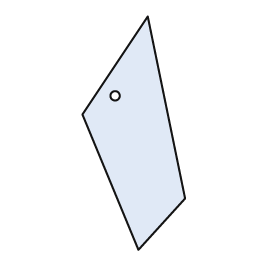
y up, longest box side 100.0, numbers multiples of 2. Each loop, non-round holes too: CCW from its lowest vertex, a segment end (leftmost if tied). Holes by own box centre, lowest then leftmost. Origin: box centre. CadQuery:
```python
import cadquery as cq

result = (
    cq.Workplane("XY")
    .moveTo(2.0, -50.0)
    .lineTo(22.0, -28.0)
    .lineTo(6.0, 50.0)
    .lineTo(-22.0, 8.0)
    .close()
    .moveTo(-8.0, 16.0)
    .circle(2.0)
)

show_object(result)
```